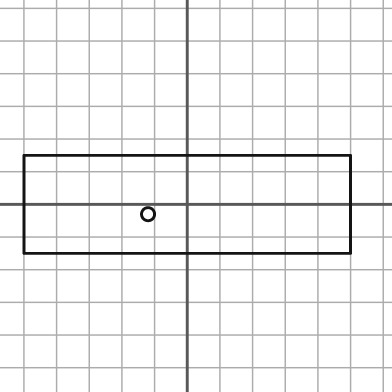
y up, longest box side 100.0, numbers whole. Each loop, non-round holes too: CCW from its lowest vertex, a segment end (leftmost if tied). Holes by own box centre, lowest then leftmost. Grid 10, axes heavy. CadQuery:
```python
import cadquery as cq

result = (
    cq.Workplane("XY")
    .moveTo(-50.0, -15.0)
    .lineTo(50.0, -15.0)
    .lineTo(50.0, 15.0)
    .lineTo(-50.0, 15.0)
    .close()
    .moveTo(-12.0, -3.0)
    .circle(2.0)
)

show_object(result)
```